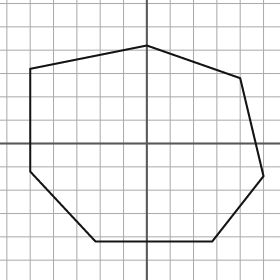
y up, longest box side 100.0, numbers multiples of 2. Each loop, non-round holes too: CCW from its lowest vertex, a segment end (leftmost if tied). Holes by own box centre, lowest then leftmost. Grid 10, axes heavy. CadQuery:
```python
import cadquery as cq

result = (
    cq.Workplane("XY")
    .moveTo(-22.0, -42.0)
    .lineTo(28.0, -42.0)
    .lineTo(50.0, -14.0)
    .lineTo(40.0, 28.0)
    .lineTo(0.0, 42.0)
    .lineTo(-50.0, 32.0)
    .lineTo(-50.0, -12.0)
    .close()
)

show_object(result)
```